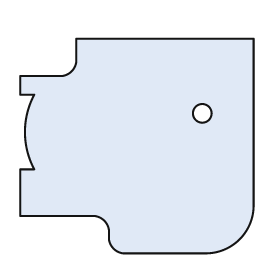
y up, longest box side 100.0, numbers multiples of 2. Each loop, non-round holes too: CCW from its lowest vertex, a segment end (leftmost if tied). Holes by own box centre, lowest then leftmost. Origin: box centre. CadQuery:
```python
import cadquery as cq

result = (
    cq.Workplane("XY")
    .moveTo(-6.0, -46.0)
    .lineTo(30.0, -46.0)
    .threePointArc((44.0, -40.0), (50.0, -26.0))
    .lineTo(50.0, 46.0)
    .lineTo(-26.0, 46.0)
    .lineTo(-26.0, 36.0)
    .threePointArc((-28.0, 32.0), (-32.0, 30.0))
    .lineTo(-50.0, 30.0)
    .lineTo(-50.0, 22.0)
    .lineTo(-44.0, 22.0)
    .threePointArc((-48.0, 6.0), (-44.0, -10.0))
    .lineTo(-50.0, -10.0)
    .lineTo(-50.0, -30.0)
    .lineTo(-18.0, -30.0)
    .threePointArc((-14.0, -32.0), (-12.0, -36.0))
    .lineTo(-12.0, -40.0)
    .threePointArc((-10.0, -44.0), (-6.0, -46.0))
    .close()
    .moveTo(28.0, 14.0)
    .circle(4.0)
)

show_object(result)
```